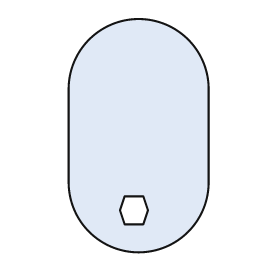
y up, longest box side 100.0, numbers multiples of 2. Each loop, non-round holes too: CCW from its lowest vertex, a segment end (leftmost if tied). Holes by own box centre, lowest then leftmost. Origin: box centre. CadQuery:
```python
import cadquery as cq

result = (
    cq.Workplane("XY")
    .moveTo(-30.0, -20.0)
    .threePointArc((0.0, -50.0), (30.0, -20.0))
    .lineTo(30.0, 20.0)
    .threePointArc((0.0, 50.0), (-30.0, 20.0))
    .close()
    .moveTo(-6.0, -38.0)
    .lineTo(2.0, -38.0)
    .lineTo(4.0, -32.0)
    .lineTo(2.0, -26.0)
    .lineTo(-6.0, -26.0)
    .lineTo(-8.0, -32.0)
    .close()
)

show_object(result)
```